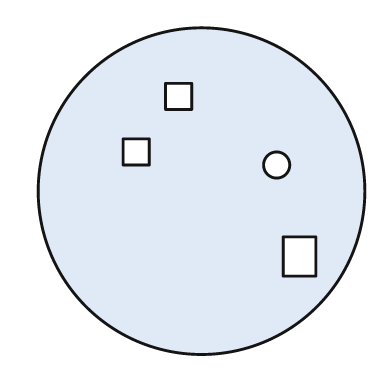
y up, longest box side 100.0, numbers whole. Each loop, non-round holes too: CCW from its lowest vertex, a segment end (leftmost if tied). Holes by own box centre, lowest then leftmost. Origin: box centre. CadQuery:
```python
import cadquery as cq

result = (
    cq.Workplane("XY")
    .moveTo(0.0, 0.0)
    .circle(50.0)
    .moveTo(25.0, -26.0)
    .lineTo(35.0, -26.0)
    .lineTo(35.0, -14.0)
    .lineTo(25.0, -14.0)
    .close()
    .moveTo(23.0, 8.0)
    .circle(4.0)
    .moveTo(-24.0, 8.0)
    .lineTo(-16.0, 8.0)
    .lineTo(-16.0, 16.0)
    .lineTo(-24.0, 16.0)
    .close()
    .moveTo(-11.0, 25.0)
    .lineTo(-3.0, 25.0)
    .lineTo(-3.0, 33.0)
    .lineTo(-11.0, 33.0)
    .close()
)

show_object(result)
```